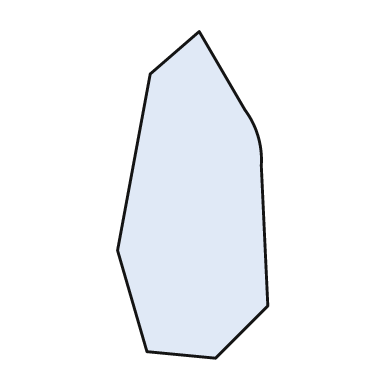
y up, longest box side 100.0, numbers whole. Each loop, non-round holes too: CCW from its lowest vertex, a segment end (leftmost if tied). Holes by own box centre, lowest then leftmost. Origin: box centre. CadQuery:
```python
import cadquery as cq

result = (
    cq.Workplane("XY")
    .moveTo(7.0, -50.0)
    .lineTo(23.0, -34.0)
    .lineTo(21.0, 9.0)
    .threePointArc((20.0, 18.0), (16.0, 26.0))
    .lineTo(2.0, 50.0)
    .lineTo(-13.0, 37.0)
    .lineTo(-23.0, -17.0)
    .lineTo(-14.0, -48.0)
    .close()
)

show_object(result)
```